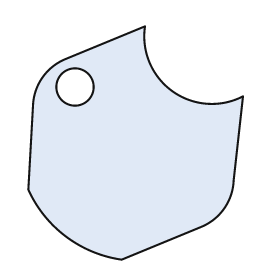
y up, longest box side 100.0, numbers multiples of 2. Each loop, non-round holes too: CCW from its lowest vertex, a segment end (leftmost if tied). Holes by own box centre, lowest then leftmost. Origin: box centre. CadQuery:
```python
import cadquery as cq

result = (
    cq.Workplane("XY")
    .moveTo(-6.0, -50.0)
    .lineTo(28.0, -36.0)
    .threePointArc((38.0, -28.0), (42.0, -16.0))
    .lineTo(46.0, 20.0)
    .threePointArc((16.0, 22.0), (4.0, 50.0))
    .lineTo(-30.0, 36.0)
    .threePointArc((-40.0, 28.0), (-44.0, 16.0))
    .lineTo(-46.0, -20.0)
    .threePointArc((-30.0, -40.0), (-6.0, -50.0))
    .close()
    .moveTo(-26.0, 24.0)
    .circle(8.0)
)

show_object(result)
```